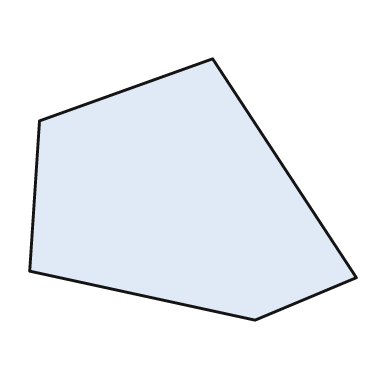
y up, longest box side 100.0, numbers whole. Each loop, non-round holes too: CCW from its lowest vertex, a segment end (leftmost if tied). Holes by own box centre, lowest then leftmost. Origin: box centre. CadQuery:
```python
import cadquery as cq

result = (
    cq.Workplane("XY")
    .moveTo(19.0, -40.0)
    .lineTo(50.0, -27.0)
    .lineTo(6.0, 40.0)
    .lineTo(-47.0, 21.0)
    .lineTo(-50.0, -25.0)
    .close()
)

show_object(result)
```